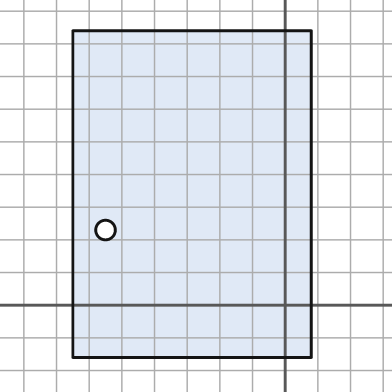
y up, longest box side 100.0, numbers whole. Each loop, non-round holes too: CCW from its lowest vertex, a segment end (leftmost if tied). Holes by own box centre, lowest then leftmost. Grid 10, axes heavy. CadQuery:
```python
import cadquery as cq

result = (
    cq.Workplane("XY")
    .moveTo(-65.0, -16.0)
    .lineTo(8.0, -16.0)
    .lineTo(8.0, 84.0)
    .lineTo(-65.0, 84.0)
    .close()
    .moveTo(-55.0, 23.0)
    .circle(3.0)
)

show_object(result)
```